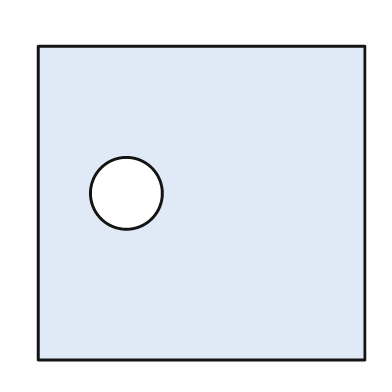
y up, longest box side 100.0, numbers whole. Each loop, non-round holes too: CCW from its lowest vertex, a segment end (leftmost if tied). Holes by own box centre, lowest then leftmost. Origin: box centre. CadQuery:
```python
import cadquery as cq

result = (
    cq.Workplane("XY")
    .moveTo(-50.0, -48.0)
    .lineTo(50.0, -48.0)
    .lineTo(50.0, 48.0)
    .lineTo(-50.0, 48.0)
    .close()
    .moveTo(-23.0, 3.0)
    .circle(11.0)
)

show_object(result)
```